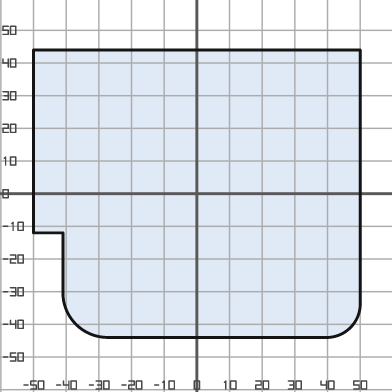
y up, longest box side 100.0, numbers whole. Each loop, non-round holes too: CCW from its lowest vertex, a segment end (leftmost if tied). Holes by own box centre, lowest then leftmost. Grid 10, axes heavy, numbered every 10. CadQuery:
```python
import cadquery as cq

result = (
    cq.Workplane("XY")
    .moveTo(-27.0, -44.0)
    .lineTo(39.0, -44.0)
    .threePointArc((47.0, -41.0), (50.0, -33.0))
    .lineTo(50.0, 44.0)
    .lineTo(-50.0, 44.0)
    .lineTo(-50.0, -12.0)
    .lineTo(-41.0, -12.0)
    .lineTo(-41.0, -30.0)
    .threePointArc((-37.0, -40.0), (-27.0, -44.0))
    .close()
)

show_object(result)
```